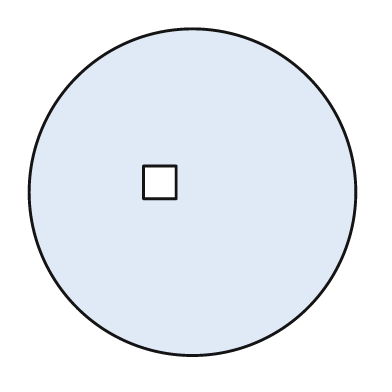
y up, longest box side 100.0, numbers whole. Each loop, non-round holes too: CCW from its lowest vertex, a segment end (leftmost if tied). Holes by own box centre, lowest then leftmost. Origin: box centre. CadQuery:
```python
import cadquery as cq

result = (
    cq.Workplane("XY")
    .moveTo(0.0, 0.0)
    .circle(50.0)
    .moveTo(-15.0, -2.0)
    .lineTo(-5.0, -2.0)
    .lineTo(-5.0, 8.0)
    .lineTo(-15.0, 8.0)
    .close()
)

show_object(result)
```